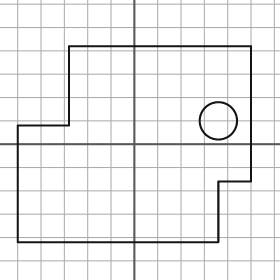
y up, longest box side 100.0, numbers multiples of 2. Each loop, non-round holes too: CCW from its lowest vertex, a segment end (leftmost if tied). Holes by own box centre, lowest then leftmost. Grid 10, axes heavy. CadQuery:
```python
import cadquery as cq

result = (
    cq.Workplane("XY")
    .moveTo(-50.0, -42.0)
    .lineTo(36.0, -42.0)
    .lineTo(36.0, -16.0)
    .lineTo(50.0, -16.0)
    .lineTo(50.0, 42.0)
    .lineTo(-28.0, 42.0)
    .lineTo(-28.0, 8.0)
    .lineTo(-50.0, 8.0)
    .close()
    .moveTo(36.0, 10.0)
    .circle(8.0)
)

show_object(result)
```